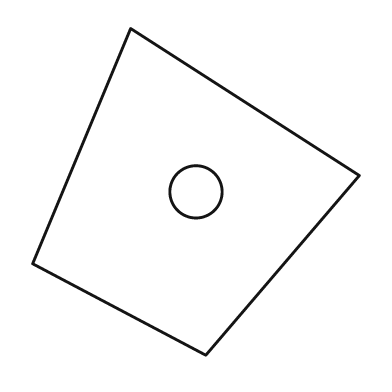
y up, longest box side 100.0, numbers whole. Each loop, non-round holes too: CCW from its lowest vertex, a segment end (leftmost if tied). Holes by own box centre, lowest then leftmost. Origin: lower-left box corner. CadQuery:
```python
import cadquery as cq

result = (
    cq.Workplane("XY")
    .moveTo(53.0, 0.0)
    .lineTo(100.0, 55.0)
    .lineTo(30.0, 100.0)
    .lineTo(0.0, 28.0)
    .close()
    .moveTo(50.0, 50.0)
    .circle(8.0)
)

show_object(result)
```